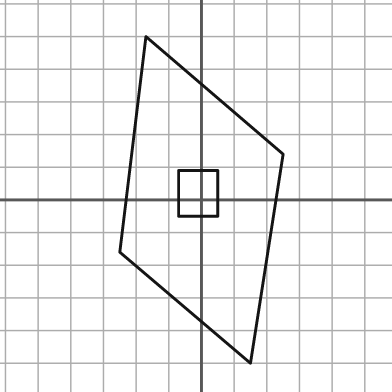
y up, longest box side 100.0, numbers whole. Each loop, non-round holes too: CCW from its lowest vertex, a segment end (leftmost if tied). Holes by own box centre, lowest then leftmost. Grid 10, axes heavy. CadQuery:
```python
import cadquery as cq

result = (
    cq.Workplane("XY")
    .moveTo(15.0, -50.0)
    .lineTo(25.0, 14.0)
    .lineTo(-17.0, 50.0)
    .lineTo(-25.0, -16.0)
    .close()
    .moveTo(-7.0, -5.0)
    .lineTo(5.0, -5.0)
    .lineTo(5.0, 9.0)
    .lineTo(-7.0, 9.0)
    .close()
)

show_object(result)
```